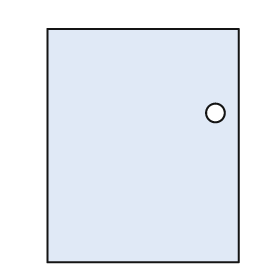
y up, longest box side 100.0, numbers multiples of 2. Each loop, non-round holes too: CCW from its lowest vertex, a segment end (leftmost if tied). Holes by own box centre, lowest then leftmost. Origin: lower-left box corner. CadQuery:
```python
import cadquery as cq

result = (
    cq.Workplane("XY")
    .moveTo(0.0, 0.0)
    .lineTo(82.0, 0.0)
    .lineTo(82.0, 100.0)
    .lineTo(0.0, 100.0)
    .close()
    .moveTo(72.0, 64.0)
    .circle(4.0)
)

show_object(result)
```